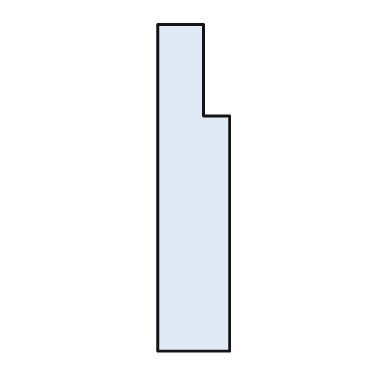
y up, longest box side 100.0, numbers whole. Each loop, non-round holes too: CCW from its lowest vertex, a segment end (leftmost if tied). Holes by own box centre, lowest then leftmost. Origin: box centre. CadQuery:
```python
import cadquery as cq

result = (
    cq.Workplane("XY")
    .moveTo(-11.0, -50.0)
    .lineTo(11.0, -50.0)
    .lineTo(11.0, 22.0)
    .lineTo(3.0, 22.0)
    .lineTo(3.0, 50.0)
    .lineTo(-11.0, 50.0)
    .close()
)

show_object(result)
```